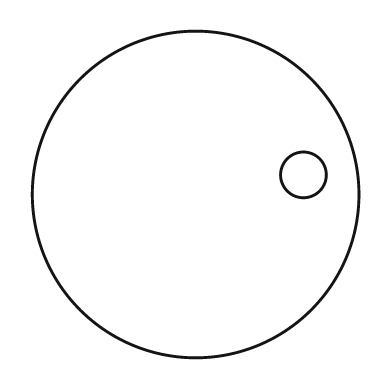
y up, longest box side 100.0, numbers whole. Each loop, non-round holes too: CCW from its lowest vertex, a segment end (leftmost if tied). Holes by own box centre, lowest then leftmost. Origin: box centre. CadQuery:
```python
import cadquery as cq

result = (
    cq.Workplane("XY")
    .moveTo(0.0, 0.0)
    .circle(50.0)
    .moveTo(33.0, 6.0)
    .circle(7.0)
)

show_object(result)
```